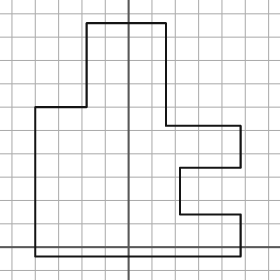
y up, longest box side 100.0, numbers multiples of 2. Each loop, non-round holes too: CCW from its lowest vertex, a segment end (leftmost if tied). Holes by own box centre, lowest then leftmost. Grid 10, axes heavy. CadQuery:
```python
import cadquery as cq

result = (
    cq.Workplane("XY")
    .moveTo(-40.0, -4.0)
    .lineTo(48.0, -4.0)
    .lineTo(48.0, 14.0)
    .lineTo(22.0, 14.0)
    .lineTo(22.0, 34.0)
    .lineTo(48.0, 34.0)
    .lineTo(48.0, 52.0)
    .lineTo(16.0, 52.0)
    .lineTo(16.0, 96.0)
    .lineTo(-18.0, 96.0)
    .lineTo(-18.0, 60.0)
    .lineTo(-40.0, 60.0)
    .close()
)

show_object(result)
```